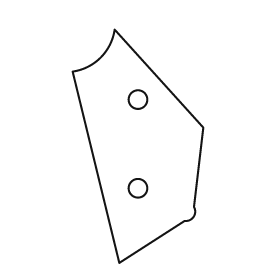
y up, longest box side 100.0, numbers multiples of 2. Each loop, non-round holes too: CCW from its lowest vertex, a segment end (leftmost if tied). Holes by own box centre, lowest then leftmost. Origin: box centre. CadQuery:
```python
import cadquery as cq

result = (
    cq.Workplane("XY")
    .moveTo(-8.0, -50.0)
    .lineTo(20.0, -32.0)
    .threePointArc((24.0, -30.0), (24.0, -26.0))
    .lineTo(28.0, 8.0)
    .lineTo(-10.0, 50.0)
    .threePointArc((-16.0, 38.0), (-28.0, 32.0))
    .close()
    .moveTo(0.0, -18.0)
    .circle(4.0)
    .moveTo(0.0, 20.0)
    .circle(4.0)
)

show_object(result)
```